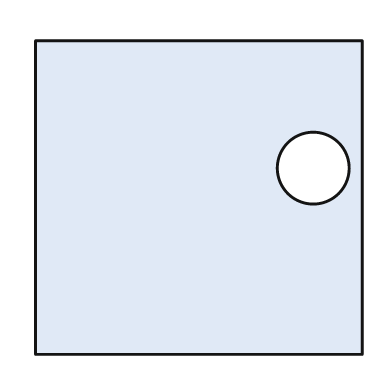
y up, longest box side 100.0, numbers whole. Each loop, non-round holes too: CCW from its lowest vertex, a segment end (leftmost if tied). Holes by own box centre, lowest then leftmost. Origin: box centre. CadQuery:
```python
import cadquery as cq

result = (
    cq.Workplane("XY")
    .moveTo(-50.0, -48.0)
    .lineTo(50.0, -48.0)
    .lineTo(50.0, 48.0)
    .lineTo(-50.0, 48.0)
    .close()
    .moveTo(35.0, 9.0)
    .circle(11.0)
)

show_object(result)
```